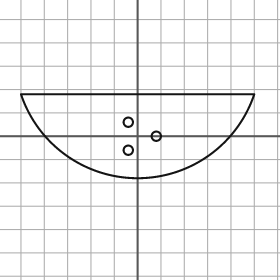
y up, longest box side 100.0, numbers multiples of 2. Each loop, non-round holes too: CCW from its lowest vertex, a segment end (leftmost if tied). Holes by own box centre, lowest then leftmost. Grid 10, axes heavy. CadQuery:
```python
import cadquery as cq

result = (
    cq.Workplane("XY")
    .moveTo(-50.0, 18.0)
    .threePointArc((0.0, -18.0), (50.0, 18.0))
    .close()
    .moveTo(-4.0, -6.0)
    .circle(2.0)
    .moveTo(8.0, 0.0)
    .circle(2.0)
    .moveTo(-4.0, 6.0)
    .circle(2.0)
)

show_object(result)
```